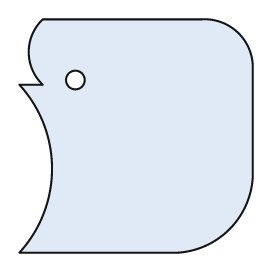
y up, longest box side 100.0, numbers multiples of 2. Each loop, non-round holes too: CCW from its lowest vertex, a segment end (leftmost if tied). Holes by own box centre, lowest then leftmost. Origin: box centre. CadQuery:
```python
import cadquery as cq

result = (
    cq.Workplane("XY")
    .moveTo(-50.0, -50.0)
    .lineTo(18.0, -50.0)
    .threePointArc((40.0, -40.0), (50.0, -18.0))
    .lineTo(50.0, 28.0)
    .threePointArc((44.0, 44.0), (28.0, 50.0))
    .lineTo(-40.0, 50.0)
    .threePointArc((-46.0, 36.0), (-40.0, 22.0))
    .lineTo(-50.0, 22.0)
    .threePointArc((-36.0, -14.0), (-50.0, -50.0))
    .close()
    .moveTo(-26.0, 24.0)
    .circle(4.0)
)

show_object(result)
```